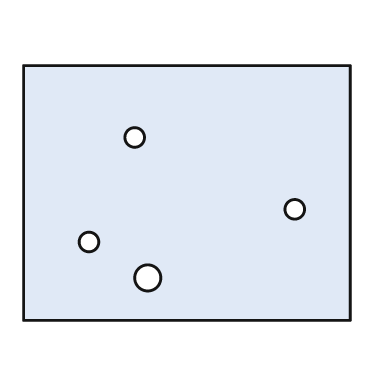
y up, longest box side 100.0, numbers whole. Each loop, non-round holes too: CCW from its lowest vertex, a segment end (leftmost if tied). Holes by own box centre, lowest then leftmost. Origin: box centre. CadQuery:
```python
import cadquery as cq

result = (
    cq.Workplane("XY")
    .moveTo(-50.0, -39.0)
    .lineTo(50.0, -39.0)
    .lineTo(50.0, 39.0)
    .lineTo(-50.0, 39.0)
    .close()
    .moveTo(-12.0, -26.0)
    .circle(4.0)
    .moveTo(-30.0, -15.0)
    .circle(3.0)
    .moveTo(33.0, -5.0)
    .circle(3.0)
    .moveTo(-16.0, 17.0)
    .circle(3.0)
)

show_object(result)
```